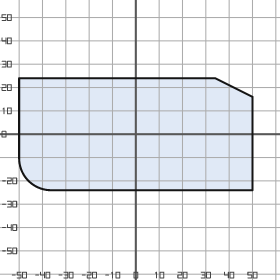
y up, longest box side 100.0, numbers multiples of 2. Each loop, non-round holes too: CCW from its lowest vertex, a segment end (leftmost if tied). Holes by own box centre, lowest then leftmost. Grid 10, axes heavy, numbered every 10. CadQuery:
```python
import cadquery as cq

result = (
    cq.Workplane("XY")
    .moveTo(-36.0, -24.0)
    .lineTo(50.0, -24.0)
    .lineTo(50.0, 16.0)
    .lineTo(34.0, 24.0)
    .lineTo(-50.0, 24.0)
    .lineTo(-50.0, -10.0)
    .threePointArc((-46.0, -20.0), (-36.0, -24.0))
    .close()
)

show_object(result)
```